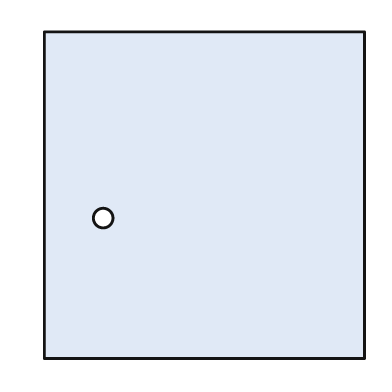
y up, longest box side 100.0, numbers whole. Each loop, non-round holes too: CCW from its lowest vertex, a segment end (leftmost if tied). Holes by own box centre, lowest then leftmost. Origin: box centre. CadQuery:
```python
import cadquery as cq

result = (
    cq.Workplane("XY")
    .moveTo(-49.0, -50.0)
    .lineTo(49.0, -50.0)
    .lineTo(49.0, 50.0)
    .lineTo(-49.0, 50.0)
    .close()
    .moveTo(-31.0, -7.0)
    .circle(3.0)
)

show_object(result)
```